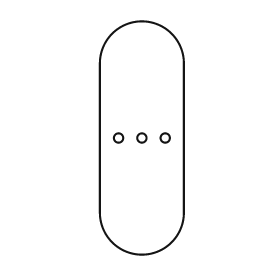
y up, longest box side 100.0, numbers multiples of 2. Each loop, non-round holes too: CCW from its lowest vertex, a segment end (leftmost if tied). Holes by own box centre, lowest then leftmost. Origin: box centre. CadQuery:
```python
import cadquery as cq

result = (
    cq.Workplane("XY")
    .moveTo(-18.0, -32.0)
    .threePointArc((0.0, -50.0), (18.0, -32.0))
    .lineTo(18.0, 32.0)
    .threePointArc((0.0, 50.0), (-18.0, 32.0))
    .close()
    .moveTo(-10.0, 0.0)
    .circle(2.0)
    .moveTo(0.0, 0.0)
    .circle(2.0)
    .moveTo(10.0, 0.0)
    .circle(2.0)
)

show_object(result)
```